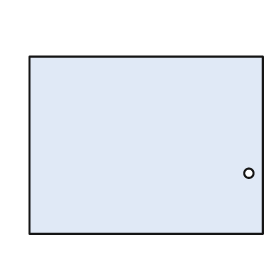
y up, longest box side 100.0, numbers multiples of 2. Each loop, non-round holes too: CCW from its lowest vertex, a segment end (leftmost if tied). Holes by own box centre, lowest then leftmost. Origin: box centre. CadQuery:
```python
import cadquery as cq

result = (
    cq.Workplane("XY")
    .moveTo(-50.0, -38.0)
    .lineTo(50.0, -38.0)
    .lineTo(50.0, 38.0)
    .lineTo(-50.0, 38.0)
    .close()
    .moveTo(44.0, -12.0)
    .circle(2.0)
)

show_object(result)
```